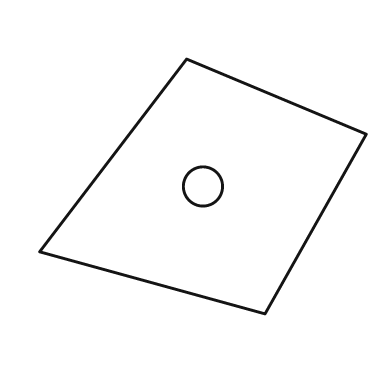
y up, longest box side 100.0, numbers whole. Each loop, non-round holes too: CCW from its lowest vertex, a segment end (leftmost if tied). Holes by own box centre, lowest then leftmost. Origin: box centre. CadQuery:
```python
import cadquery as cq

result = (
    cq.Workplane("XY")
    .moveTo(19.0, -39.0)
    .lineTo(50.0, 16.0)
    .lineTo(-5.0, 39.0)
    .lineTo(-50.0, -20.0)
    .close()
    .moveTo(0.0, 0.0)
    .circle(6.0)
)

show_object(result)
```